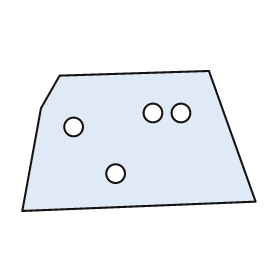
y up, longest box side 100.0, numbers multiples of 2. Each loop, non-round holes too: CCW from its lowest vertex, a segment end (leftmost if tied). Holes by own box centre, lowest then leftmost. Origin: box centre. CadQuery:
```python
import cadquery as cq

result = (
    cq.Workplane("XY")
    .moveTo(-50.0, -30.0)
    .lineTo(50.0, -26.0)
    .lineTo(30.0, 30.0)
    .lineTo(-34.0, 28.0)
    .lineTo(-42.0, 14.0)
    .close()
    .moveTo(-10.0, -14.0)
    .circle(4.0)
    .moveTo(-28.0, 6.0)
    .circle(4.0)
    .moveTo(6.0, 12.0)
    .circle(4.0)
    .moveTo(18.0, 12.0)
    .circle(4.0)
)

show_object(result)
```